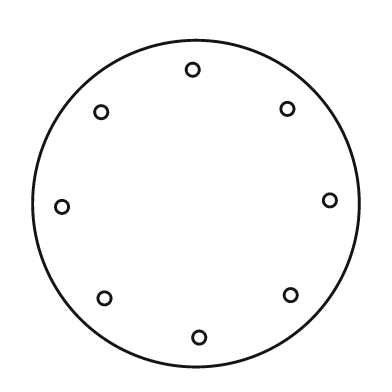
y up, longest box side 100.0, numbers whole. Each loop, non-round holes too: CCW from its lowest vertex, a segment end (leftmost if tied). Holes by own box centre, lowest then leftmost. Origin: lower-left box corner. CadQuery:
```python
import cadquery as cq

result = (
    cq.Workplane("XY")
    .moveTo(50.0, 50.0)
    .circle(50.0)
    .moveTo(51.0, 9.0)
    .circle(2.0)
    .moveTo(22.0, 21.0)
    .circle(2.0)
    .moveTo(79.0, 22.0)
    .circle(2.0)
    .moveTo(9.0, 49.0)
    .circle(2.0)
    .moveTo(91.0, 51.0)
    .circle(2.0)
    .moveTo(21.0, 78.0)
    .circle(2.0)
    .moveTo(78.0, 79.0)
    .circle(2.0)
    .moveTo(49.0, 91.0)
    .circle(2.0)
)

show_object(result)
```